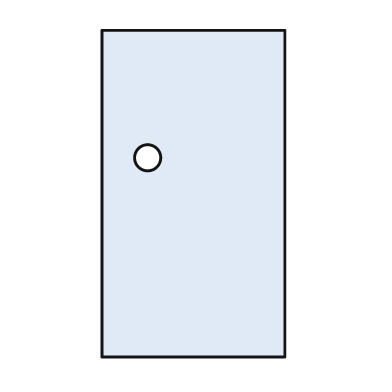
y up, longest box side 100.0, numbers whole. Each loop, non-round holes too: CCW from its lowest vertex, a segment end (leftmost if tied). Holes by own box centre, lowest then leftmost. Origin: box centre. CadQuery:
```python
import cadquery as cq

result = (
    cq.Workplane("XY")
    .moveTo(-28.0, -50.0)
    .lineTo(28.0, -50.0)
    .lineTo(28.0, 50.0)
    .lineTo(-28.0, 50.0)
    .close()
    .moveTo(-14.0, 11.0)
    .circle(4.0)
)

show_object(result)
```